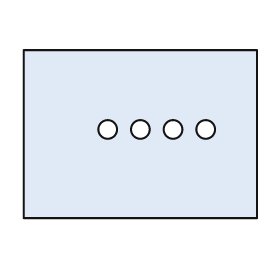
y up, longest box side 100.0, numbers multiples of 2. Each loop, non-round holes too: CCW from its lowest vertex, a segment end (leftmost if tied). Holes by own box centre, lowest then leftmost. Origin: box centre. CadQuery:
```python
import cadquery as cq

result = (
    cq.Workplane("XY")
    .moveTo(-50.0, -36.0)
    .lineTo(50.0, -36.0)
    .lineTo(50.0, 36.0)
    .lineTo(-50.0, 36.0)
    .close()
    .moveTo(-14.0, 2.0)
    .circle(4.0)
    .moveTo(0.0, 2.0)
    .circle(4.0)
    .moveTo(14.0, 2.0)
    .circle(4.0)
    .moveTo(28.0, 2.0)
    .circle(4.0)
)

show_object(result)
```